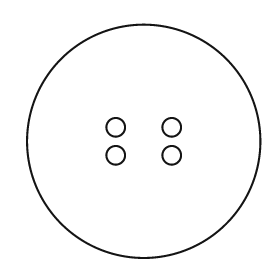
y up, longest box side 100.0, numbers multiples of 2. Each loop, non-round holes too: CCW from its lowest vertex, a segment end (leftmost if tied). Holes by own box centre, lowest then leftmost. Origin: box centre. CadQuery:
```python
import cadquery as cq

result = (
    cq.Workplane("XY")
    .moveTo(0.0, 0.0)
    .circle(50.0)
    .moveTo(-12.0, -6.0)
    .circle(4.0)
    .moveTo(12.0, -6.0)
    .circle(4.0)
    .moveTo(-12.0, 6.0)
    .circle(4.0)
    .moveTo(12.0, 6.0)
    .circle(4.0)
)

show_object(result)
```